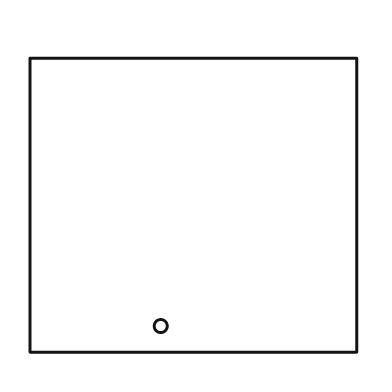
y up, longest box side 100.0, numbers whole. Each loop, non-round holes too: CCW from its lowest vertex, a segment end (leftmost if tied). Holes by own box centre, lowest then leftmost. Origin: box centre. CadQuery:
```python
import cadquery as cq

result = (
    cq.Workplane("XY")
    .moveTo(-50.0, -45.0)
    .lineTo(50.0, -45.0)
    .lineTo(50.0, 45.0)
    .lineTo(-50.0, 45.0)
    .close()
    .moveTo(-10.0, -37.0)
    .circle(2.0)
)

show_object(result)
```